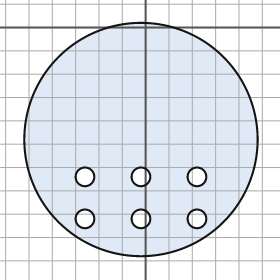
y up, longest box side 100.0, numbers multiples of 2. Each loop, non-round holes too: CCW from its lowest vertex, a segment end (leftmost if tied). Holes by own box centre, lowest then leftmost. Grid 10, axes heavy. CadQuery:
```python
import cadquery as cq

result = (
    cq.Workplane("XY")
    .moveTo(-2.0, -48.0)
    .circle(50.0)
    .moveTo(-26.0, -82.0)
    .circle(4.0)
    .moveTo(-2.0, -82.0)
    .circle(4.0)
    .moveTo(22.0, -82.0)
    .circle(4.0)
    .moveTo(-26.0, -64.0)
    .circle(4.0)
    .moveTo(-2.0, -64.0)
    .circle(4.0)
    .moveTo(22.0, -64.0)
    .circle(4.0)
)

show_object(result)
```